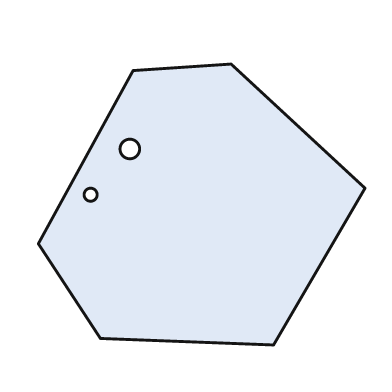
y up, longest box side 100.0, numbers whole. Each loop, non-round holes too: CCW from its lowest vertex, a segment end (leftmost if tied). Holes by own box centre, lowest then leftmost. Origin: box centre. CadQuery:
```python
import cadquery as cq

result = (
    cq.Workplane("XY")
    .moveTo(22.0, -43.0)
    .lineTo(50.0, 5.0)
    .lineTo(9.0, 43.0)
    .lineTo(-21.0, 41.0)
    .lineTo(-50.0, -12.0)
    .lineTo(-31.0, -41.0)
    .close()
    .moveTo(-34.0, 3.0)
    .circle(2.0)
    .moveTo(-22.0, 17.0)
    .circle(3.0)
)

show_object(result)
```